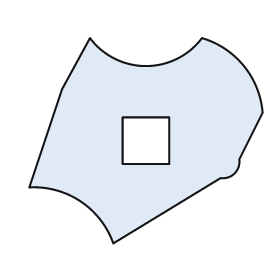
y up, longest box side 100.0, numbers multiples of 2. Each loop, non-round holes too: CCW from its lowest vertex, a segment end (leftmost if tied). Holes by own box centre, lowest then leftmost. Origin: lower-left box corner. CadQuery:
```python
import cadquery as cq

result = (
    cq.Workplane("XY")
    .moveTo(36.0, 0.0)
    .lineTo(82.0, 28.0)
    .threePointArc((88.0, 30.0), (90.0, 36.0))
    .lineTo(100.0, 56.0)
    .threePointArc((92.0, 76.0), (74.0, 88.0))
    .threePointArc((50.0, 76.0), (26.0, 88.0))
    .lineTo(14.0, 66.0)
    .lineTo(0.0, 24.0)
    .threePointArc((22.0, 18.0), (36.0, 0.0))
    .close()
    .moveTo(40.0, 34.0)
    .lineTo(60.0, 34.0)
    .lineTo(60.0, 54.0)
    .lineTo(40.0, 54.0)
    .close()
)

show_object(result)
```